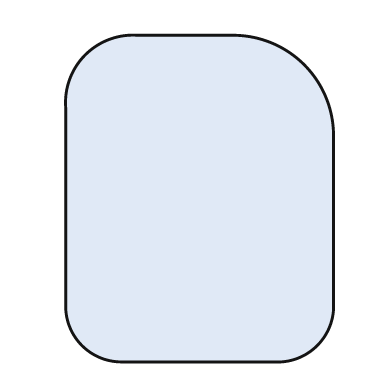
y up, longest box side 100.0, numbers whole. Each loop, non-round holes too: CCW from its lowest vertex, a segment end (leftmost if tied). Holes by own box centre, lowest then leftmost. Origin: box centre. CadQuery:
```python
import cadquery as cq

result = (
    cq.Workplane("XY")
    .moveTo(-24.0, -50.0)
    .lineTo(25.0, -50.0)
    .threePointArc((36.0, -45.0), (41.0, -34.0))
    .lineTo(41.0, 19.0)
    .threePointArc((32.0, 41.0), (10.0, 50.0))
    .lineTo(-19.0, 50.0)
    .threePointArc((-35.0, 44.0), (-41.0, 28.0))
    .lineTo(-41.0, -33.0)
    .threePointArc((-36.0, -45.0), (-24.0, -50.0))
    .close()
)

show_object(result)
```